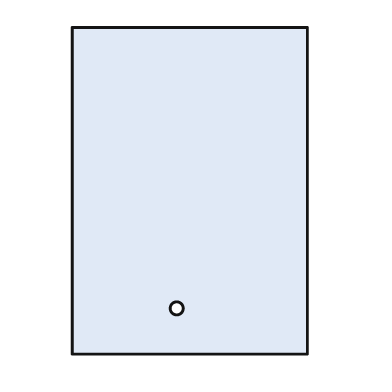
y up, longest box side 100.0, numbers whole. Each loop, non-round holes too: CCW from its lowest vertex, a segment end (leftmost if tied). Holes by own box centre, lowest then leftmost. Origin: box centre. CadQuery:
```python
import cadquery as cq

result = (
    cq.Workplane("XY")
    .moveTo(-36.0, -50.0)
    .lineTo(36.0, -50.0)
    .lineTo(36.0, 50.0)
    .lineTo(-36.0, 50.0)
    .close()
    .moveTo(-4.0, -36.0)
    .circle(2.0)
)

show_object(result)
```